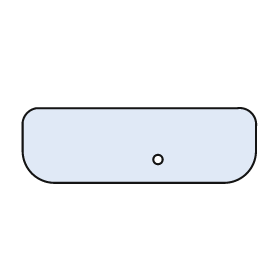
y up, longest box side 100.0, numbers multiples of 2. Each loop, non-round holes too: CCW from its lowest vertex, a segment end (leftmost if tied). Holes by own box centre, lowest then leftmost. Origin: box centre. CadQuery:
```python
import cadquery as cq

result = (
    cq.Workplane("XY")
    .moveTo(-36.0, -16.0)
    .lineTo(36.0, -16.0)
    .threePointArc((46.0, -12.0), (50.0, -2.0))
    .lineTo(50.0, 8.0)
    .threePointArc((48.0, 14.0), (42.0, 16.0))
    .lineTo(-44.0, 16.0)
    .threePointArc((-48.0, 14.0), (-50.0, 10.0))
    .lineTo(-50.0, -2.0)
    .threePointArc((-46.0, -12.0), (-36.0, -16.0))
    .close()
    .moveTo(8.0, -6.0)
    .circle(2.0)
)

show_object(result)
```